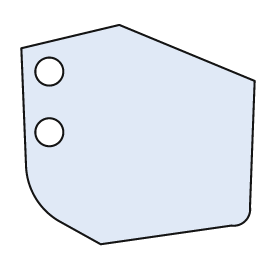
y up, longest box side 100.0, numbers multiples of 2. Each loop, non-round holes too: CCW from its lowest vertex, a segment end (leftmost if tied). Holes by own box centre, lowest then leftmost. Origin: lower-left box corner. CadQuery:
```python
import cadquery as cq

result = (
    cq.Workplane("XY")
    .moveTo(34.0, 0.0)
    .lineTo(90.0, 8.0)
    .threePointArc((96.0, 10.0), (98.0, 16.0))
    .lineTo(100.0, 70.0)
    .lineTo(42.0, 94.0)
    .lineTo(0.0, 84.0)
    .lineTo(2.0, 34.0)
    .threePointArc((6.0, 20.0), (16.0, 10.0))
    .close()
    .moveTo(12.0, 48.0)
    .circle(6.0)
    .moveTo(12.0, 74.0)
    .circle(6.0)
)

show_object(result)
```